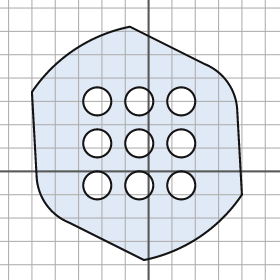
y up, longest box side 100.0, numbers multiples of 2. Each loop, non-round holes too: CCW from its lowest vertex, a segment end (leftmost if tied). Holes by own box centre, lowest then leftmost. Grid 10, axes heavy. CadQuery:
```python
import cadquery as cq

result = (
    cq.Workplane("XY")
    .moveTo(-2.0, -38.0)
    .threePointArc((22.0, -28.0), (40.0, -10.0))
    .lineTo(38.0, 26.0)
    .threePointArc((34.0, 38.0), (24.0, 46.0))
    .lineTo(-8.0, 62.0)
    .threePointArc((-32.0, 52.0), (-50.0, 34.0))
    .lineTo(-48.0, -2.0)
    .threePointArc((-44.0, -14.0), (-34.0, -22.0))
    .close()
    .moveTo(-22.0, -6.0)
    .circle(6.0)
    .moveTo(-4.0, -6.0)
    .circle(6.0)
    .moveTo(14.0, -6.0)
    .circle(6.0)
    .moveTo(-22.0, 12.0)
    .circle(6.0)
    .moveTo(-4.0, 12.0)
    .circle(6.0)
    .moveTo(14.0, 12.0)
    .circle(6.0)
    .moveTo(-22.0, 30.0)
    .circle(6.0)
    .moveTo(-4.0, 30.0)
    .circle(6.0)
    .moveTo(14.0, 30.0)
    .circle(6.0)
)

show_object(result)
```